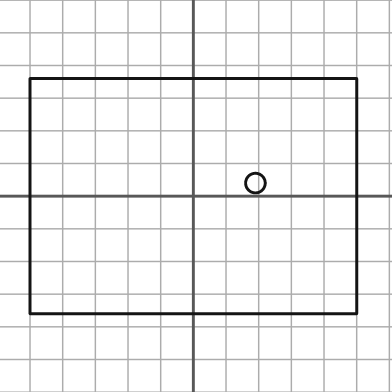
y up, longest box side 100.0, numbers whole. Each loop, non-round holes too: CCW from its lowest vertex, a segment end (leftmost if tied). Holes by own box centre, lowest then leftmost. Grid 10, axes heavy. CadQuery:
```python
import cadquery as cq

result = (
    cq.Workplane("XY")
    .moveTo(-50.0, -36.0)
    .lineTo(50.0, -36.0)
    .lineTo(50.0, 36.0)
    .lineTo(-50.0, 36.0)
    .close()
    .moveTo(19.0, 4.0)
    .circle(3.0)
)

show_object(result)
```